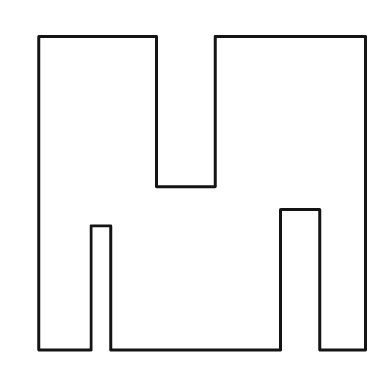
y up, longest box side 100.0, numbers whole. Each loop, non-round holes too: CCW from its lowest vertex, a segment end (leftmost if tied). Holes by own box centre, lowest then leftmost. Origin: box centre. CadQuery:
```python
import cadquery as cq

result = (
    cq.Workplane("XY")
    .moveTo(-50.0, -48.0)
    .lineTo(-34.0, -48.0)
    .lineTo(-34.0, -10.0)
    .lineTo(-28.0, -10.0)
    .lineTo(-28.0, -48.0)
    .lineTo(24.0, -48.0)
    .lineTo(24.0, -5.0)
    .lineTo(36.0, -5.0)
    .lineTo(36.0, -48.0)
    .lineTo(50.0, -48.0)
    .lineTo(50.0, 48.0)
    .lineTo(4.0, 48.0)
    .lineTo(4.0, 2.0)
    .lineTo(-14.0, 2.0)
    .lineTo(-14.0, 48.0)
    .lineTo(-50.0, 48.0)
    .close()
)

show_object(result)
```